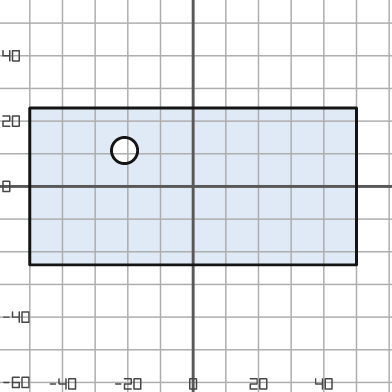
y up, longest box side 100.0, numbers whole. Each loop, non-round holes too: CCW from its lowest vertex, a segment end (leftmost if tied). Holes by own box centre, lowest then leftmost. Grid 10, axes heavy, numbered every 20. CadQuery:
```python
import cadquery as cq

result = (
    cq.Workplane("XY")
    .moveTo(-50.0, -24.0)
    .lineTo(50.0, -24.0)
    .lineTo(50.0, 24.0)
    .lineTo(-50.0, 24.0)
    .close()
    .moveTo(-21.0, 11.0)
    .circle(4.0)
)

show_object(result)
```